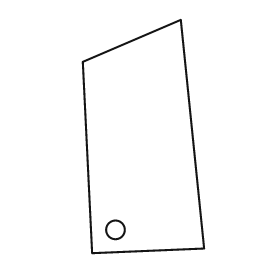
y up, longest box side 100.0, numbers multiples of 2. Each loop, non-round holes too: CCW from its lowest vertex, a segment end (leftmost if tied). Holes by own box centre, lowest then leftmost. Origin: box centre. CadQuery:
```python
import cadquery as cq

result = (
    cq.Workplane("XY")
    .moveTo(-22.0, -50.0)
    .lineTo(26.0, -48.0)
    .lineTo(16.0, 50.0)
    .lineTo(-26.0, 32.0)
    .close()
    .moveTo(-12.0, -40.0)
    .circle(4.0)
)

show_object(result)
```